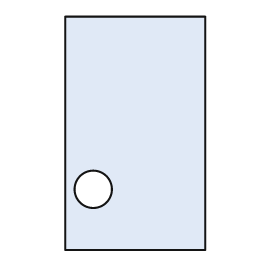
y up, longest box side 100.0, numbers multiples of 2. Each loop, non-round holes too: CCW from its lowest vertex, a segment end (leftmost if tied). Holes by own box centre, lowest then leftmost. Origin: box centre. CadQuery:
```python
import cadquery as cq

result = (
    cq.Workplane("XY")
    .moveTo(-30.0, -50.0)
    .lineTo(30.0, -50.0)
    .lineTo(30.0, 50.0)
    .lineTo(-30.0, 50.0)
    .close()
    .moveTo(-18.0, -24.0)
    .circle(8.0)
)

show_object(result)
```